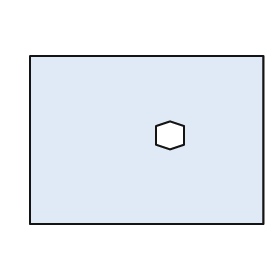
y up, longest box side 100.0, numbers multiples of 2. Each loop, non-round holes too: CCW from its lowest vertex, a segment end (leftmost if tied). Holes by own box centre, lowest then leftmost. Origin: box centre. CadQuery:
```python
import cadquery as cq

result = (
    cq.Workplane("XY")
    .moveTo(-50.0, -36.0)
    .lineTo(50.0, -36.0)
    .lineTo(50.0, 36.0)
    .lineTo(-50.0, 36.0)
    .close()
    .moveTo(10.0, -4.0)
    .lineTo(16.0, -2.0)
    .lineTo(16.0, 6.0)
    .lineTo(10.0, 8.0)
    .lineTo(4.0, 6.0)
    .lineTo(4.0, -2.0)
    .close()
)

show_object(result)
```